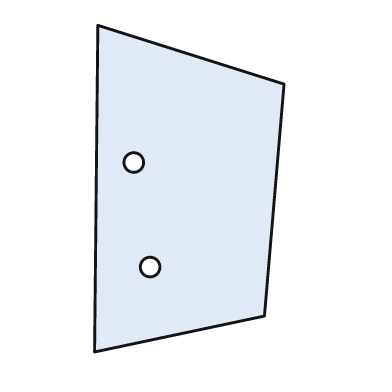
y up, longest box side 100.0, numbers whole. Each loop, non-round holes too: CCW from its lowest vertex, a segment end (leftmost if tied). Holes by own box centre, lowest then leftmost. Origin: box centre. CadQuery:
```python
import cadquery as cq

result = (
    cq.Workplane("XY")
    .moveTo(-29.0, -50.0)
    .lineTo(23.0, -39.0)
    .lineTo(29.0, 32.0)
    .lineTo(-28.0, 50.0)
    .close()
    .moveTo(-12.0, -24.0)
    .circle(3.0)
    .moveTo(-17.0, 8.0)
    .circle(3.0)
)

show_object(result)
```